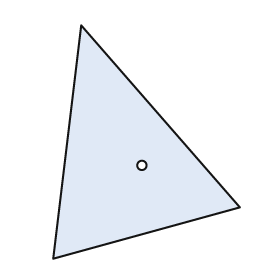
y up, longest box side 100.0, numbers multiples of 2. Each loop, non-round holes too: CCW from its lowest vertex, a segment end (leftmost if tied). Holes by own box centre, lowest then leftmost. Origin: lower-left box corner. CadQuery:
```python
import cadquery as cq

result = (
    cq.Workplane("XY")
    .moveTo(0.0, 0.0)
    .lineTo(80.0, 22.0)
    .lineTo(12.0, 100.0)
    .close()
    .moveTo(38.0, 40.0)
    .circle(2.0)
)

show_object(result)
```